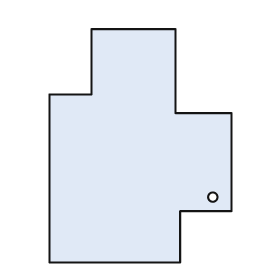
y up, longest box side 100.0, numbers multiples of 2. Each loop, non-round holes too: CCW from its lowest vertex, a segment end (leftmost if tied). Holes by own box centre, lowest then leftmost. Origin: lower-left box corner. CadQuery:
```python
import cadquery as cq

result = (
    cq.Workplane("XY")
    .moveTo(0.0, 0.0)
    .lineTo(56.0, 0.0)
    .lineTo(56.0, 22.0)
    .lineTo(78.0, 22.0)
    .lineTo(78.0, 64.0)
    .lineTo(54.0, 64.0)
    .lineTo(54.0, 100.0)
    .lineTo(18.0, 100.0)
    .lineTo(18.0, 72.0)
    .lineTo(0.0, 72.0)
    .close()
    .moveTo(70.0, 28.0)
    .circle(2.0)
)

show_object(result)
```